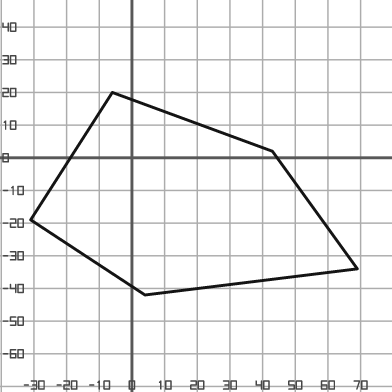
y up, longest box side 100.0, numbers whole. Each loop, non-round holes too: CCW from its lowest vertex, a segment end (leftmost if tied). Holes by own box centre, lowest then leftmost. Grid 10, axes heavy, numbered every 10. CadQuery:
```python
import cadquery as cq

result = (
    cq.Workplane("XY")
    .moveTo(4.0, -42.0)
    .lineTo(69.0, -34.0)
    .lineTo(43.0, 2.0)
    .lineTo(-6.0, 20.0)
    .lineTo(-31.0, -19.0)
    .close()
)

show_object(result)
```